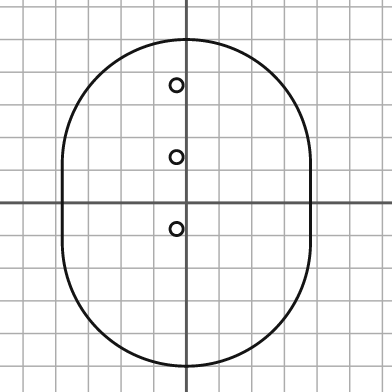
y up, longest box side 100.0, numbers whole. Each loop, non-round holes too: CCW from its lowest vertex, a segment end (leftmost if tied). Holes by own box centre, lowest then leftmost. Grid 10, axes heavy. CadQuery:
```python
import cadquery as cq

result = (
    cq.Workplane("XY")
    .moveTo(-38.0, -12.0)
    .threePointArc((0.0, -50.0), (38.0, -12.0))
    .lineTo(38.0, 12.0)
    .threePointArc((0.0, 50.0), (-38.0, 12.0))
    .close()
    .moveTo(-3.0, -8.0)
    .circle(2.0)
    .moveTo(-3.0, 14.0)
    .circle(2.0)
    .moveTo(-3.0, 36.0)
    .circle(2.0)
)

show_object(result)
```